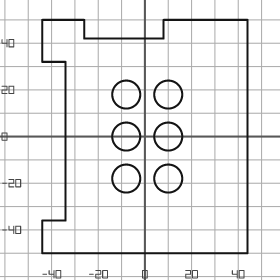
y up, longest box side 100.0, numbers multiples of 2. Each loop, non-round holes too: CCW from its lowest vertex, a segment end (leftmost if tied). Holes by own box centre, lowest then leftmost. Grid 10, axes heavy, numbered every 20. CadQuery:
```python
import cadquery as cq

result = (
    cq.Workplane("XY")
    .moveTo(-44.0, -50.0)
    .lineTo(44.0, -50.0)
    .lineTo(44.0, 50.0)
    .lineTo(8.0, 50.0)
    .lineTo(8.0, 42.0)
    .lineTo(-26.0, 42.0)
    .lineTo(-26.0, 50.0)
    .lineTo(-44.0, 50.0)
    .lineTo(-44.0, 32.0)
    .lineTo(-34.0, 32.0)
    .lineTo(-34.0, -36.0)
    .lineTo(-44.0, -36.0)
    .close()
    .moveTo(-8.0, -18.0)
    .circle(6.0)
    .moveTo(10.0, -18.0)
    .circle(6.0)
    .moveTo(-8.0, 0.0)
    .circle(6.0)
    .moveTo(10.0, 0.0)
    .circle(6.0)
    .moveTo(-8.0, 18.0)
    .circle(6.0)
    .moveTo(10.0, 18.0)
    .circle(6.0)
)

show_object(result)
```